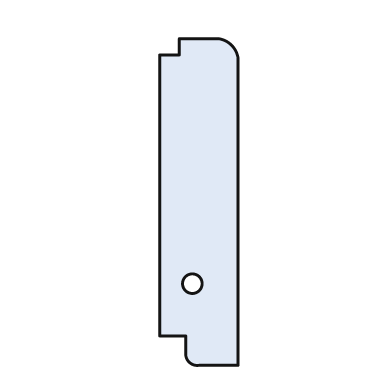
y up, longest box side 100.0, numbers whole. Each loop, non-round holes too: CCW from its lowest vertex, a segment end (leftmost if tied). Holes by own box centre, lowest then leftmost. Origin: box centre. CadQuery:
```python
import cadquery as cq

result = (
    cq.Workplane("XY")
    .moveTo(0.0, -50.0)
    .lineTo(12.0, -50.0)
    .lineTo(12.0, 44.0)
    .threePointArc((10.0, 48.0), (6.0, 50.0))
    .lineTo(-6.0, 50.0)
    .lineTo(-6.0, 45.0)
    .lineTo(-12.0, 45.0)
    .lineTo(-12.0, -41.0)
    .lineTo(-4.0, -41.0)
    .lineTo(-4.0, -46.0)
    .threePointArc((-3.0, -49.0), (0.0, -50.0))
    .close()
    .moveTo(-2.0, -25.0)
    .circle(3.0)
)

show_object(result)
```